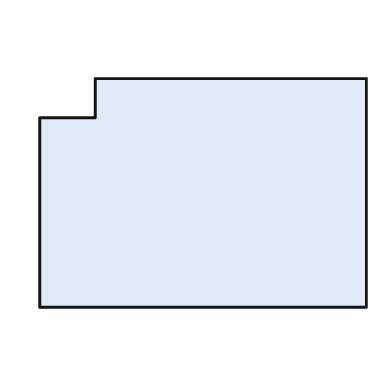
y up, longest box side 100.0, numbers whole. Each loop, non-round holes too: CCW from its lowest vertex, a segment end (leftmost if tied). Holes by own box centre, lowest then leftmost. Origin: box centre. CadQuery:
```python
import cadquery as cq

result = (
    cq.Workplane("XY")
    .moveTo(-50.0, -35.0)
    .lineTo(50.0, -35.0)
    .lineTo(50.0, 35.0)
    .lineTo(-33.0, 35.0)
    .lineTo(-33.0, 23.0)
    .lineTo(-50.0, 23.0)
    .close()
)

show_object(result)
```